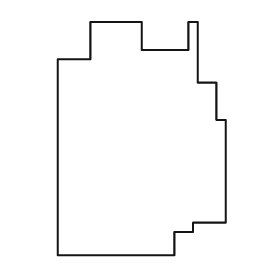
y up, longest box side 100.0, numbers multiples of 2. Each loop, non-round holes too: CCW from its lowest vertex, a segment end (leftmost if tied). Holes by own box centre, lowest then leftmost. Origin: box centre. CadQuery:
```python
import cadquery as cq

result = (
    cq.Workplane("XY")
    .moveTo(-36.0, -50.0)
    .lineTo(14.0, -50.0)
    .lineTo(14.0, -40.0)
    .lineTo(22.0, -40.0)
    .lineTo(22.0, -36.0)
    .lineTo(36.0, -36.0)
    .lineTo(36.0, 8.0)
    .lineTo(32.0, 8.0)
    .lineTo(32.0, 24.0)
    .lineTo(24.0, 24.0)
    .lineTo(24.0, 50.0)
    .lineTo(20.0, 50.0)
    .lineTo(20.0, 38.0)
    .lineTo(0.0, 38.0)
    .lineTo(0.0, 50.0)
    .lineTo(-22.0, 50.0)
    .lineTo(-22.0, 34.0)
    .lineTo(-36.0, 34.0)
    .close()
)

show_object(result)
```